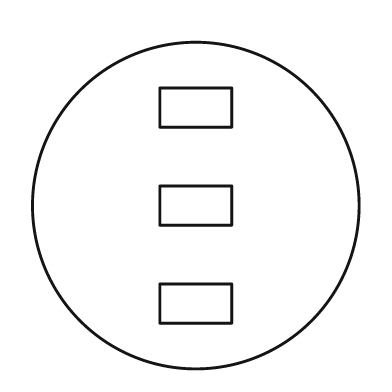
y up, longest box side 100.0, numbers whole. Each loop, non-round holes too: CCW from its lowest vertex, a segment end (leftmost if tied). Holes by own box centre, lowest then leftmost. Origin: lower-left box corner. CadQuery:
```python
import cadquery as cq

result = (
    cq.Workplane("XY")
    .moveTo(50.0, 50.0)
    .circle(50.0)
    .moveTo(39.0, 14.0)
    .lineTo(61.0, 14.0)
    .lineTo(61.0, 26.0)
    .lineTo(39.0, 26.0)
    .close()
    .moveTo(39.0, 44.0)
    .lineTo(61.0, 44.0)
    .lineTo(61.0, 56.0)
    .lineTo(39.0, 56.0)
    .close()
    .moveTo(39.0, 74.0)
    .lineTo(61.0, 74.0)
    .lineTo(61.0, 86.0)
    .lineTo(39.0, 86.0)
    .close()
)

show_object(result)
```